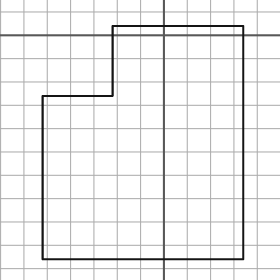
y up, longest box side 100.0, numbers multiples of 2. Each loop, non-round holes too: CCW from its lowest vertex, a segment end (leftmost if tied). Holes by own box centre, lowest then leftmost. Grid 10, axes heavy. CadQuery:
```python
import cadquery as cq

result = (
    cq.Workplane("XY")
    .moveTo(-52.0, -96.0)
    .lineTo(34.0, -96.0)
    .lineTo(34.0, 4.0)
    .lineTo(-22.0, 4.0)
    .lineTo(-22.0, -26.0)
    .lineTo(-52.0, -26.0)
    .close()
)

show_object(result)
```